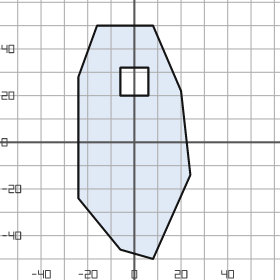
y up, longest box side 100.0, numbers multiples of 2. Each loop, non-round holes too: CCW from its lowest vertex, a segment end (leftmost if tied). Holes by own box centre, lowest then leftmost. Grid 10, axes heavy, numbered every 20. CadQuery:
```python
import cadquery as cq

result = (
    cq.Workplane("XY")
    .moveTo(8.0, -50.0)
    .lineTo(24.0, -14.0)
    .lineTo(20.0, 22.0)
    .lineTo(8.0, 50.0)
    .lineTo(-16.0, 50.0)
    .lineTo(-24.0, 28.0)
    .lineTo(-24.0, -24.0)
    .lineTo(-6.0, -46.0)
    .close()
    .moveTo(-6.0, 20.0)
    .lineTo(6.0, 20.0)
    .lineTo(6.0, 32.0)
    .lineTo(-6.0, 32.0)
    .close()
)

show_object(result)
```